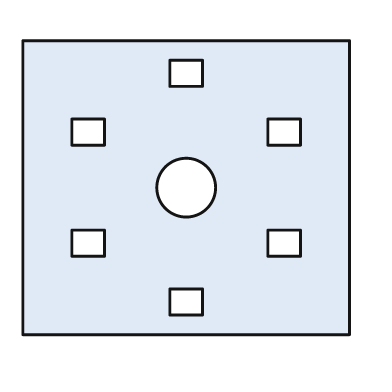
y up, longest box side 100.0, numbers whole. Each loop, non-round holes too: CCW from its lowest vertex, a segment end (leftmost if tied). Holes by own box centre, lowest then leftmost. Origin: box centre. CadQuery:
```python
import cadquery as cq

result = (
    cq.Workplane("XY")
    .moveTo(-50.0, -45.0)
    .lineTo(50.0, -45.0)
    .lineTo(50.0, 45.0)
    .lineTo(-50.0, 45.0)
    .close()
    .moveTo(-5.0, -39.0)
    .lineTo(5.0, -39.0)
    .lineTo(5.0, -31.0)
    .lineTo(-5.0, -31.0)
    .close()
    .moveTo(-35.0, -21.0)
    .lineTo(-25.0, -21.0)
    .lineTo(-25.0, -13.0)
    .lineTo(-35.0, -13.0)
    .close()
    .moveTo(25.0, -21.0)
    .lineTo(35.0, -21.0)
    .lineTo(35.0, -13.0)
    .lineTo(25.0, -13.0)
    .close()
    .moveTo(0.0, 0.0)
    .circle(9.0)
    .moveTo(-35.0, 13.0)
    .lineTo(-25.0, 13.0)
    .lineTo(-25.0, 21.0)
    .lineTo(-35.0, 21.0)
    .close()
    .moveTo(25.0, 13.0)
    .lineTo(35.0, 13.0)
    .lineTo(35.0, 21.0)
    .lineTo(25.0, 21.0)
    .close()
    .moveTo(-5.0, 31.0)
    .lineTo(5.0, 31.0)
    .lineTo(5.0, 39.0)
    .lineTo(-5.0, 39.0)
    .close()
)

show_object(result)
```